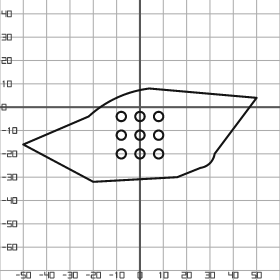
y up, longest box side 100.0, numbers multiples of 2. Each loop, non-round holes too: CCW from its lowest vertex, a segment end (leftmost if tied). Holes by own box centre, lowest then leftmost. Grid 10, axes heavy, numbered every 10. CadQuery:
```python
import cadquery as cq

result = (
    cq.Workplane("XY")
    .moveTo(-20.0, -32.0)
    .lineTo(16.0, -30.0)
    .lineTo(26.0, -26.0)
    .threePointArc((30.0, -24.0), (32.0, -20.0))
    .lineTo(50.0, 4.0)
    .lineTo(4.0, 8.0)
    .threePointArc((-10.0, 4.0), (-22.0, -4.0))
    .lineTo(-50.0, -16.0)
    .close()
    .moveTo(-8.0, -20.0)
    .circle(2.0)
    .moveTo(0.0, -20.0)
    .circle(2.0)
    .moveTo(8.0, -20.0)
    .circle(2.0)
    .moveTo(-8.0, -12.0)
    .circle(2.0)
    .moveTo(0.0, -12.0)
    .circle(2.0)
    .moveTo(8.0, -12.0)
    .circle(2.0)
    .moveTo(-8.0, -4.0)
    .circle(2.0)
    .moveTo(0.0, -4.0)
    .circle(2.0)
    .moveTo(8.0, -4.0)
    .circle(2.0)
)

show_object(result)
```